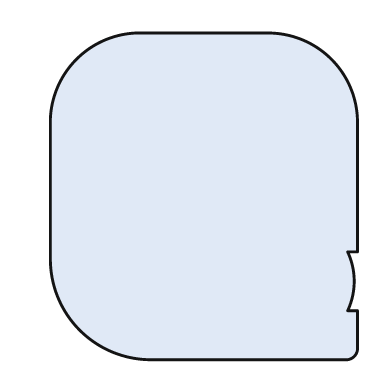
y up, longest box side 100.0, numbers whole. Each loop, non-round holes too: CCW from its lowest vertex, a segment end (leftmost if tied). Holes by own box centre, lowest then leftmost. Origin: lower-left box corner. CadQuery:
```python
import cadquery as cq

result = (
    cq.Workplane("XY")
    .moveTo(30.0, 0.0)
    .lineTo(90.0, 0.0)
    .threePointArc((93.0, 1.0), (94.0, 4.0))
    .lineTo(94.0, 15.0)
    .lineTo(91.0, 15.0)
    .threePointArc((93.0, 24.0), (91.0, 33.0))
    .lineTo(94.0, 33.0)
    .lineTo(94.0, 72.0)
    .threePointArc((86.0, 92.0), (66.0, 100.0))
    .lineTo(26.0, 100.0)
    .threePointArc((8.0, 92.0), (0.0, 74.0))
    .lineTo(0.0, 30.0)
    .threePointArc((9.0, 9.0), (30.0, 0.0))
    .close()
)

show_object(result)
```